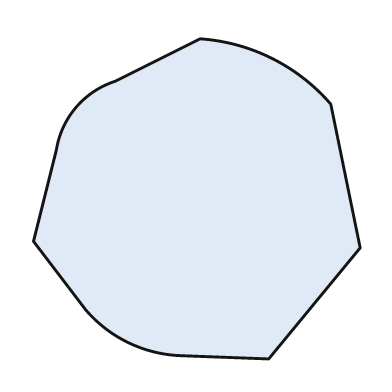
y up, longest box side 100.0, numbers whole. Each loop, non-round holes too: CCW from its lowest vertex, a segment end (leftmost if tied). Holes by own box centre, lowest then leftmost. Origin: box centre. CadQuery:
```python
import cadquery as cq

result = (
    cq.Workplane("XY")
    .moveTo(22.0, -49.0)
    .lineTo(50.0, -15.0)
    .lineTo(41.0, 29.0)
    .threePointArc((23.0, 43.0), (1.0, 49.0))
    .lineTo(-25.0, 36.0)
    .threePointArc((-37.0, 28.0), (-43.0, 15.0))
    .lineTo(-50.0, -13.0)
    .lineTo(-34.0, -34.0)
    .threePointArc((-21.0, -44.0), (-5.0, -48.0))
    .close()
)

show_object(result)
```